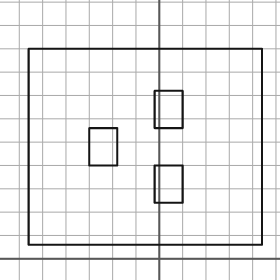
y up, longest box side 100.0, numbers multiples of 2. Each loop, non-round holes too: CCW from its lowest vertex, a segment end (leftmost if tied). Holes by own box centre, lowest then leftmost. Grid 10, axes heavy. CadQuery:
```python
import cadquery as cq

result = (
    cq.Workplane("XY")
    .moveTo(-56.0, 6.0)
    .lineTo(44.0, 6.0)
    .lineTo(44.0, 90.0)
    .lineTo(-56.0, 90.0)
    .close()
    .moveTo(-2.0, 24.0)
    .lineTo(10.0, 24.0)
    .lineTo(10.0, 40.0)
    .lineTo(-2.0, 40.0)
    .close()
    .moveTo(-30.0, 40.0)
    .lineTo(-18.0, 40.0)
    .lineTo(-18.0, 56.0)
    .lineTo(-30.0, 56.0)
    .close()
    .moveTo(-2.0, 56.0)
    .lineTo(10.0, 56.0)
    .lineTo(10.0, 72.0)
    .lineTo(-2.0, 72.0)
    .close()
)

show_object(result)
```